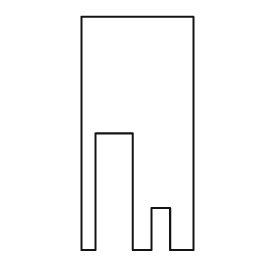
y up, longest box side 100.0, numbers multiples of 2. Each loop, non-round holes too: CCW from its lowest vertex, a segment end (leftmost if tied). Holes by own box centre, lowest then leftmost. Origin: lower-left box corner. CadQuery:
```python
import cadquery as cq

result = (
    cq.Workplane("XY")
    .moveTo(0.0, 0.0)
    .lineTo(6.0, 0.0)
    .lineTo(6.0, 50.0)
    .lineTo(22.0, 50.0)
    .lineTo(22.0, 0.0)
    .lineTo(30.0, 0.0)
    .lineTo(30.0, 18.0)
    .lineTo(38.0, 18.0)
    .lineTo(38.0, 0.0)
    .lineTo(48.0, 0.0)
    .lineTo(48.0, 100.0)
    .lineTo(0.0, 100.0)
    .close()
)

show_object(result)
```